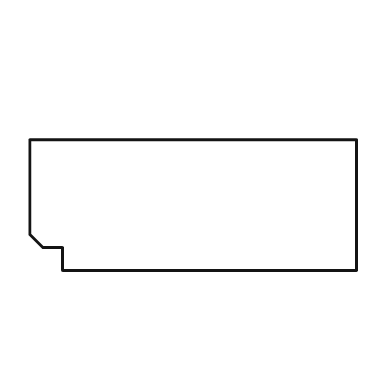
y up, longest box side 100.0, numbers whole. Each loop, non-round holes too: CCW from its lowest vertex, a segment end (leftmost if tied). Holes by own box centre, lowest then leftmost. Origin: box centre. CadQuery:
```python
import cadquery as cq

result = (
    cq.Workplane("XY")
    .moveTo(-40.0, -20.0)
    .lineTo(50.0, -20.0)
    .lineTo(50.0, 20.0)
    .lineTo(-50.0, 20.0)
    .lineTo(-50.0, -9.0)
    .lineTo(-46.0, -13.0)
    .lineTo(-40.0, -13.0)
    .close()
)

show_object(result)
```